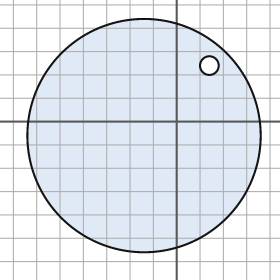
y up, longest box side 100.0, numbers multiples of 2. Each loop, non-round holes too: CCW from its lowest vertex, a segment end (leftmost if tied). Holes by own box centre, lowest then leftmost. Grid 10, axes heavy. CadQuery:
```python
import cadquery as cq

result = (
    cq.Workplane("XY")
    .moveTo(-14.0, -6.0)
    .circle(50.0)
    .moveTo(14.0, 24.0)
    .circle(4.0)
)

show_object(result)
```